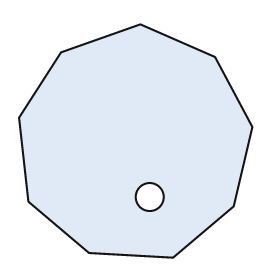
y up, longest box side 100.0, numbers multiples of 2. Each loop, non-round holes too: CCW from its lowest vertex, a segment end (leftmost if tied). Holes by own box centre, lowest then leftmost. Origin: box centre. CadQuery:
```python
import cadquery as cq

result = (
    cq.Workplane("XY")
    .moveTo(16.0, -50.0)
    .lineTo(42.0, -28.0)
    .lineTo(50.0, 6.0)
    .lineTo(34.0, 36.0)
    .lineTo(2.0, 50.0)
    .lineTo(-32.0, 38.0)
    .lineTo(-50.0, 10.0)
    .lineTo(-46.0, -26.0)
    .lineTo(-20.0, -48.0)
    .close()
    .moveTo(6.0, -24.0)
    .circle(6.0)
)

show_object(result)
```